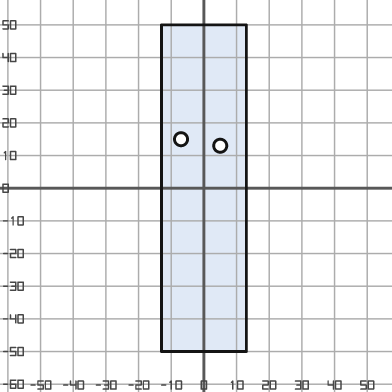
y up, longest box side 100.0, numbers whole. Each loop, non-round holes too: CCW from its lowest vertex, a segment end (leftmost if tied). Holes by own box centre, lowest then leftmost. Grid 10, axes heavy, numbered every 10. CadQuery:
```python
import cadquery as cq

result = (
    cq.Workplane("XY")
    .moveTo(-13.0, -50.0)
    .lineTo(13.0, -50.0)
    .lineTo(13.0, 50.0)
    .lineTo(-13.0, 50.0)
    .close()
    .moveTo(5.0, 13.0)
    .circle(2.0)
    .moveTo(-7.0, 15.0)
    .circle(2.0)
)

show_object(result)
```